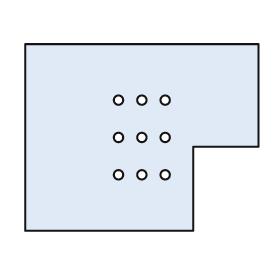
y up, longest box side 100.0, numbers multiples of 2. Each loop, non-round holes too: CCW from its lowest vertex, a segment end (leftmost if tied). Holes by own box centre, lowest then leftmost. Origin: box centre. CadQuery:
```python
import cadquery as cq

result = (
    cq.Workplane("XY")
    .moveTo(-50.0, -40.0)
    .lineTo(22.0, -40.0)
    .lineTo(22.0, -4.0)
    .lineTo(50.0, -4.0)
    .lineTo(50.0, 40.0)
    .lineTo(-50.0, 40.0)
    .close()
    .moveTo(-10.0, -16.0)
    .circle(2.0)
    .moveTo(0.0, -16.0)
    .circle(2.0)
    .moveTo(10.0, -16.0)
    .circle(2.0)
    .moveTo(-10.0, 0.0)
    .circle(2.0)
    .moveTo(0.0, 0.0)
    .circle(2.0)
    .moveTo(10.0, 0.0)
    .circle(2.0)
    .moveTo(-10.0, 16.0)
    .circle(2.0)
    .moveTo(0.0, 16.0)
    .circle(2.0)
    .moveTo(10.0, 16.0)
    .circle(2.0)
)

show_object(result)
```